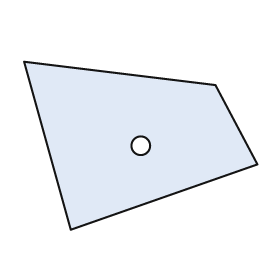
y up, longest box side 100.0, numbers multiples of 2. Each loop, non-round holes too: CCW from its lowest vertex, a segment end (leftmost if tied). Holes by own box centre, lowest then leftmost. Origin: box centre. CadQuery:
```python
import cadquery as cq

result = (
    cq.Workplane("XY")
    .moveTo(-30.0, -36.0)
    .lineTo(50.0, -8.0)
    .lineTo(32.0, 26.0)
    .lineTo(-50.0, 36.0)
    .close()
    .moveTo(0.0, 0.0)
    .circle(4.0)
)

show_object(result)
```